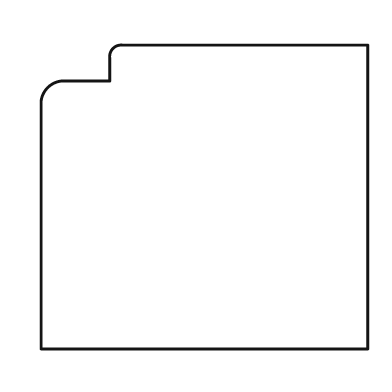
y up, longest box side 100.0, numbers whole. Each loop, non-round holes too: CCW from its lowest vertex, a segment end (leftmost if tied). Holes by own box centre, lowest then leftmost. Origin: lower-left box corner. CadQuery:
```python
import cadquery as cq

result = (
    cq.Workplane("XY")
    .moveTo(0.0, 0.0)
    .lineTo(100.0, 0.0)
    .lineTo(100.0, 93.0)
    .lineTo(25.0, 93.0)
    .threePointArc((22.0, 92.0), (21.0, 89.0))
    .lineTo(21.0, 82.0)
    .lineTo(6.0, 82.0)
    .threePointArc((2.0, 80.0), (0.0, 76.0))
    .close()
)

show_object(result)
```